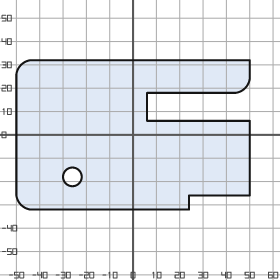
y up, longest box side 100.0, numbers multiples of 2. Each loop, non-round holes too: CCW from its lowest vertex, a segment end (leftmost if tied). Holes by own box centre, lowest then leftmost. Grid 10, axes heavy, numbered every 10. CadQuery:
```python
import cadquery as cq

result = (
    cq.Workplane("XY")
    .moveTo(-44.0, -32.0)
    .lineTo(24.0, -32.0)
    .lineTo(24.0, -26.0)
    .lineTo(50.0, -26.0)
    .lineTo(50.0, 6.0)
    .lineTo(6.0, 6.0)
    .lineTo(6.0, 18.0)
    .lineTo(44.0, 18.0)
    .threePointArc((48.0, 20.0), (50.0, 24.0))
    .lineTo(50.0, 32.0)
    .lineTo(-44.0, 32.0)
    .threePointArc((-48.0, 30.0), (-50.0, 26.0))
    .lineTo(-50.0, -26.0)
    .threePointArc((-48.0, -30.0), (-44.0, -32.0))
    .close()
    .moveTo(-26.0, -18.0)
    .circle(4.0)
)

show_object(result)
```